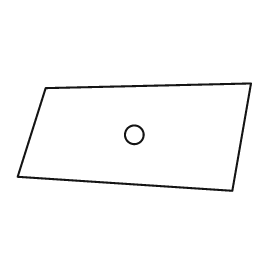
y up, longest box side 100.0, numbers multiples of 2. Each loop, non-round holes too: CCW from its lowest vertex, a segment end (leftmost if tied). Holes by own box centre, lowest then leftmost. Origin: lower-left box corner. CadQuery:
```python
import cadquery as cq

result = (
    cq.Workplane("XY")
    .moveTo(92.0, 0.0)
    .lineTo(100.0, 46.0)
    .lineTo(12.0, 44.0)
    .lineTo(0.0, 6.0)
    .close()
    .moveTo(50.0, 24.0)
    .circle(4.0)
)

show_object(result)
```